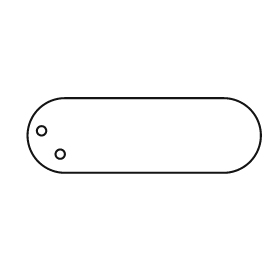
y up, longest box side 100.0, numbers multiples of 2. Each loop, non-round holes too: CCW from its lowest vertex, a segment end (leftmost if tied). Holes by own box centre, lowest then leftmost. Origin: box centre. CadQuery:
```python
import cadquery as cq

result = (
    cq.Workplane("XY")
    .moveTo(-34.0, -16.0)
    .lineTo(34.0, -16.0)
    .threePointArc((50.0, 0.0), (34.0, 16.0))
    .lineTo(-34.0, 16.0)
    .threePointArc((-50.0, 0.0), (-34.0, -16.0))
    .close()
    .moveTo(-36.0, -8.0)
    .circle(2.0)
    .moveTo(-44.0, 2.0)
    .circle(2.0)
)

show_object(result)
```